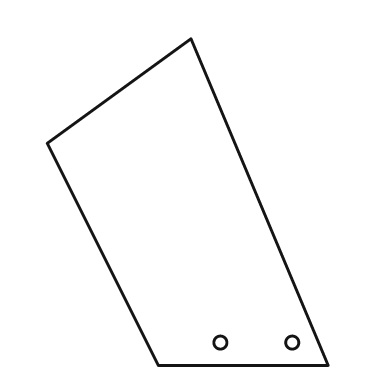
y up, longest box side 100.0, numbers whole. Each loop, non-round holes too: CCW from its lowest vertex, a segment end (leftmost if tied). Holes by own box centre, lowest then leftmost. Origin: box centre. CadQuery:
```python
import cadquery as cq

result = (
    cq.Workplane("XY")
    .moveTo(-9.0, -50.0)
    .lineTo(43.0, -50.0)
    .lineTo(1.0, 50.0)
    .lineTo(-43.0, 18.0)
    .close()
    .moveTo(10.0, -43.0)
    .circle(2.0)
    .moveTo(32.0, -43.0)
    .circle(2.0)
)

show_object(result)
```